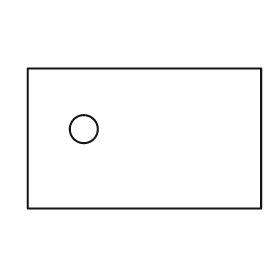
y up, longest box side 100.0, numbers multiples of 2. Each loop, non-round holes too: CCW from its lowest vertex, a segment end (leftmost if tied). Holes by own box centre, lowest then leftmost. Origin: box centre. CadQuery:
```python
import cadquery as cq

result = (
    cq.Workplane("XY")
    .moveTo(-50.0, -30.0)
    .lineTo(50.0, -30.0)
    .lineTo(50.0, 30.0)
    .lineTo(-50.0, 30.0)
    .close()
    .moveTo(-26.0, 4.0)
    .circle(6.0)
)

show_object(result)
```